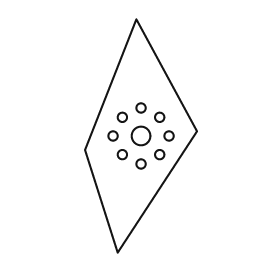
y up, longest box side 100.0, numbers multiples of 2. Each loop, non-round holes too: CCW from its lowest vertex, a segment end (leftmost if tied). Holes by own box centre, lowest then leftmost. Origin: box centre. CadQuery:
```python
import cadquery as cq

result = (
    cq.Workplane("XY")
    .moveTo(-10.0, -50.0)
    .lineTo(24.0, 2.0)
    .lineTo(-2.0, 50.0)
    .lineTo(-24.0, -6.0)
    .close()
    .moveTo(0.0, -12.0)
    .circle(2.0)
    .moveTo(-8.0, -8.0)
    .circle(2.0)
    .moveTo(8.0, -8.0)
    .circle(2.0)
    .moveTo(-12.0, 0.0)
    .circle(2.0)
    .moveTo(0.0, 0.0)
    .circle(4.0)
    .moveTo(12.0, 0.0)
    .circle(2.0)
    .moveTo(-8.0, 8.0)
    .circle(2.0)
    .moveTo(8.0, 8.0)
    .circle(2.0)
    .moveTo(0.0, 12.0)
    .circle(2.0)
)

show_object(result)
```